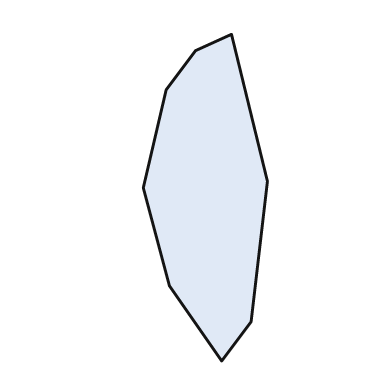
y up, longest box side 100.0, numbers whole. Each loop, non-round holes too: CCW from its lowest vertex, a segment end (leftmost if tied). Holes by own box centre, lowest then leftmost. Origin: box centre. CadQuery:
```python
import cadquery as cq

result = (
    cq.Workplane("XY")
    .moveTo(5.0, -50.0)
    .lineTo(14.0, -38.0)
    .lineTo(19.0, 5.0)
    .lineTo(8.0, 50.0)
    .lineTo(-3.0, 45.0)
    .lineTo(-12.0, 33.0)
    .lineTo(-19.0, 3.0)
    .lineTo(-11.0, -27.0)
    .close()
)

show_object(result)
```